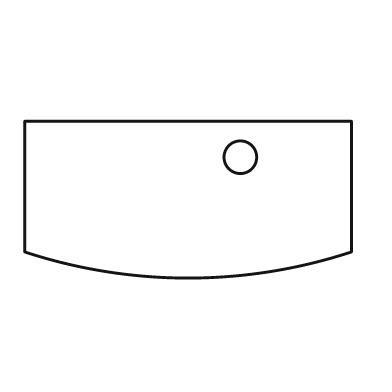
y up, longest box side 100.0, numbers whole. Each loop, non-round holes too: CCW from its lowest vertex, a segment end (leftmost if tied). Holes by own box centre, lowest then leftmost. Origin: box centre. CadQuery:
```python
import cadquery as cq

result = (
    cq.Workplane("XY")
    .moveTo(-50.0, -16.0)
    .threePointArc((0.0, -24.0), (50.0, -16.0))
    .lineTo(50.0, 24.0)
    .lineTo(-50.0, 24.0)
    .close()
    .moveTo(16.0, 13.0)
    .circle(5.0)
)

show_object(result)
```